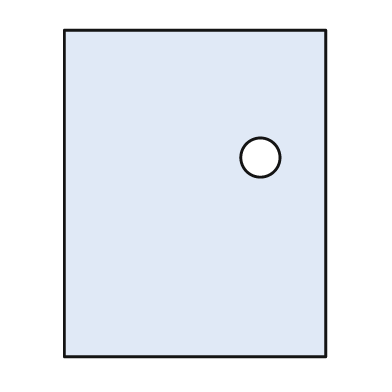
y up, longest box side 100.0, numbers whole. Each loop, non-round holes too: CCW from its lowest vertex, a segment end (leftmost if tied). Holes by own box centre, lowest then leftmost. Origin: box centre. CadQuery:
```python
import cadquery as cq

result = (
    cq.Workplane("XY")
    .moveTo(-40.0, -50.0)
    .lineTo(40.0, -50.0)
    .lineTo(40.0, 50.0)
    .lineTo(-40.0, 50.0)
    .close()
    .moveTo(20.0, 11.0)
    .circle(6.0)
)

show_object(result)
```